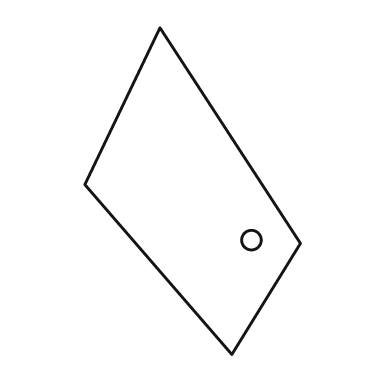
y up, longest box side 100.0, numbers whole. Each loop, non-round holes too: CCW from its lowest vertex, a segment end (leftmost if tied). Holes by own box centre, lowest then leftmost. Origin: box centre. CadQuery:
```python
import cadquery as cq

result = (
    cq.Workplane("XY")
    .moveTo(12.0, -50.0)
    .lineTo(33.0, -16.0)
    .lineTo(-10.0, 50.0)
    .lineTo(-33.0, 2.0)
    .close()
    .moveTo(18.0, -15.0)
    .circle(3.0)
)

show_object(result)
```